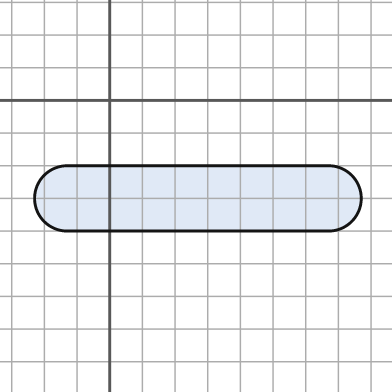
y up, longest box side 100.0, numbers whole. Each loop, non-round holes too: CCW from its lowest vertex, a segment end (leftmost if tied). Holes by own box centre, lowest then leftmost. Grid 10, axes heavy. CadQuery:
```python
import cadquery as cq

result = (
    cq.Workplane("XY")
    .moveTo(-13.0, -40.0)
    .lineTo(67.0, -40.0)
    .threePointArc((77.0, -30.0), (67.0, -20.0))
    .lineTo(-13.0, -20.0)
    .threePointArc((-23.0, -30.0), (-13.0, -40.0))
    .close()
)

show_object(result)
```